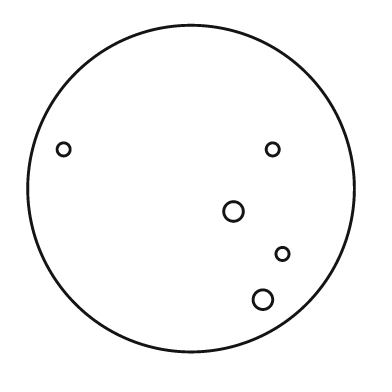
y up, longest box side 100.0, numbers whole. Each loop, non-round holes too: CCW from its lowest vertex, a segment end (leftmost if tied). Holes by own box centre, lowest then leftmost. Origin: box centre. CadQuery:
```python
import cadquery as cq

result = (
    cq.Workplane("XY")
    .moveTo(0.0, 0.0)
    .circle(50.0)
    .moveTo(22.0, -34.0)
    .circle(3.0)
    .moveTo(28.0, -20.0)
    .circle(2.0)
    .moveTo(13.0, -7.0)
    .circle(3.0)
    .moveTo(-39.0, 12.0)
    .circle(2.0)
    .moveTo(25.0, 12.0)
    .circle(2.0)
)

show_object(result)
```